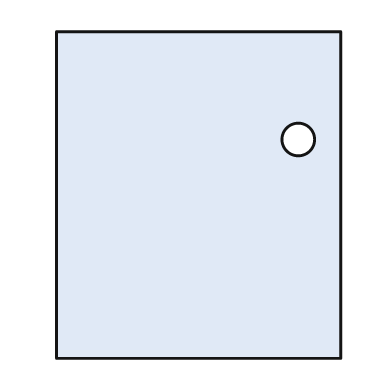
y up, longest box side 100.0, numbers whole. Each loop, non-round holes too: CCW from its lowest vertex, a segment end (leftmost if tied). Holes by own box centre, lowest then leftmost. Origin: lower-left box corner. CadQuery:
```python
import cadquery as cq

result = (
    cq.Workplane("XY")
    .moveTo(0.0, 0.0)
    .lineTo(87.0, 0.0)
    .lineTo(87.0, 100.0)
    .lineTo(0.0, 100.0)
    .close()
    .moveTo(74.0, 67.0)
    .circle(5.0)
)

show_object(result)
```